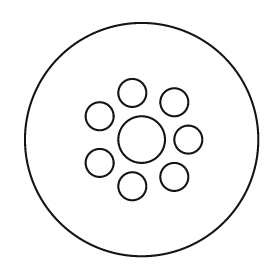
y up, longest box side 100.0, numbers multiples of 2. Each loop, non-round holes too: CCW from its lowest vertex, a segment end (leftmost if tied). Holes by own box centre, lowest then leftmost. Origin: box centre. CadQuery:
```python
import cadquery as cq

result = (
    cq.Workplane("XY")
    .moveTo(0.0, 0.0)
    .circle(50.0)
    .moveTo(-4.0, -20.0)
    .circle(6.0)
    .moveTo(14.0, -16.0)
    .circle(6.0)
    .moveTo(-18.0, -10.0)
    .circle(6.0)
    .moveTo(0.0, 0.0)
    .circle(10.0)
    .moveTo(20.0, 0.0)
    .circle(6.0)
    .moveTo(-18.0, 10.0)
    .circle(6.0)
    .moveTo(14.0, 16.0)
    .circle(6.0)
    .moveTo(-4.0, 20.0)
    .circle(6.0)
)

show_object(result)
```